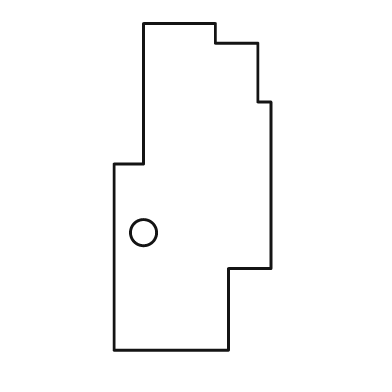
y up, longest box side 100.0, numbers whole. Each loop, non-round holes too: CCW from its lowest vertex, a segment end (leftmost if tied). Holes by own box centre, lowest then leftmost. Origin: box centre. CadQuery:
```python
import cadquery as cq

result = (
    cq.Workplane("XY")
    .moveTo(-24.0, -50.0)
    .lineTo(11.0, -50.0)
    .lineTo(11.0, -25.0)
    .lineTo(24.0, -25.0)
    .lineTo(24.0, 26.0)
    .lineTo(20.0, 26.0)
    .lineTo(20.0, 44.0)
    .lineTo(7.0, 44.0)
    .lineTo(7.0, 50.0)
    .lineTo(-15.0, 50.0)
    .lineTo(-15.0, 7.0)
    .lineTo(-24.0, 7.0)
    .close()
    .moveTo(-15.0, -14.0)
    .circle(4.0)
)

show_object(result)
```